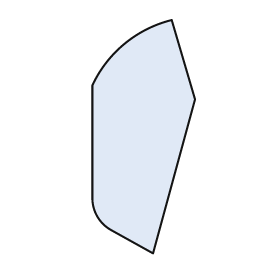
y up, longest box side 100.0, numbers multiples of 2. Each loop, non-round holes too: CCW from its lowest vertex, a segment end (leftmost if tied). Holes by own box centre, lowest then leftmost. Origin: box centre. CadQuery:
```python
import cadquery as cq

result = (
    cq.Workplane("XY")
    .moveTo(4.0, -50.0)
    .lineTo(22.0, 16.0)
    .lineTo(12.0, 50.0)
    .threePointArc((-8.0, 40.0), (-22.0, 22.0))
    .lineTo(-22.0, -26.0)
    .threePointArc((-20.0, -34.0), (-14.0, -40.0))
    .close()
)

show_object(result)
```